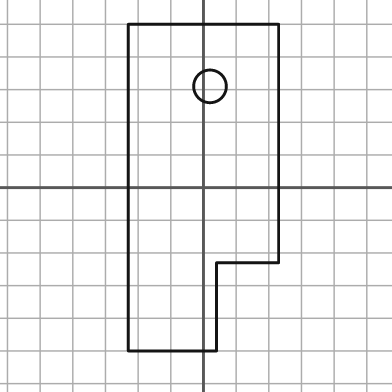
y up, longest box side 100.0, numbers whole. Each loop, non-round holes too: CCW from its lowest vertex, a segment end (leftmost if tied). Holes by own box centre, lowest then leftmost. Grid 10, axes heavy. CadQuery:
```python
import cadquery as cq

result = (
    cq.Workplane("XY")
    .moveTo(-23.0, -50.0)
    .lineTo(4.0, -50.0)
    .lineTo(4.0, -23.0)
    .lineTo(23.0, -23.0)
    .lineTo(23.0, 50.0)
    .lineTo(-23.0, 50.0)
    .close()
    .moveTo(2.0, 31.0)
    .circle(5.0)
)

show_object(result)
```